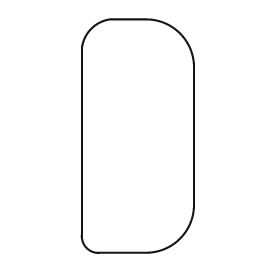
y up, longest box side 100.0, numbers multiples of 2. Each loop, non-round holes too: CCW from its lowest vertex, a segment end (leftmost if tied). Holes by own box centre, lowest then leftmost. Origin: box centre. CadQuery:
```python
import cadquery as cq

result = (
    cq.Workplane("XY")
    .moveTo(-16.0, -50.0)
    .lineTo(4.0, -50.0)
    .threePointArc((18.0, -44.0), (24.0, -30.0))
    .lineTo(24.0, 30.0)
    .threePointArc((18.0, 44.0), (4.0, 50.0))
    .lineTo(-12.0, 50.0)
    .threePointArc((-20.0, 46.0), (-24.0, 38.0))
    .lineTo(-24.0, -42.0)
    .threePointArc((-22.0, -48.0), (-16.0, -50.0))
    .close()
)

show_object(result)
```